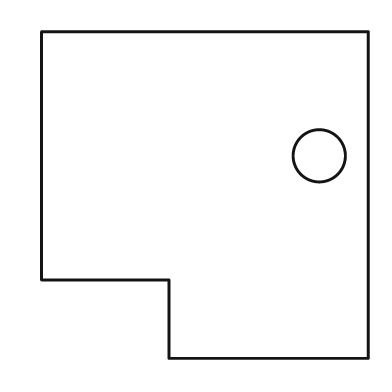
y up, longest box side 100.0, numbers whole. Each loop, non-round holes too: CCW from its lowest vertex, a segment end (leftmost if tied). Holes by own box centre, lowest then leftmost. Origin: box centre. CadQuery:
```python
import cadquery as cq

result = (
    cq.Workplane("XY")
    .moveTo(-11.0, -50.0)
    .lineTo(50.0, -50.0)
    .lineTo(50.0, 50.0)
    .lineTo(-50.0, 50.0)
    .lineTo(-50.0, -26.0)
    .lineTo(-11.0, -26.0)
    .close()
    .moveTo(35.0, 12.0)
    .circle(8.0)
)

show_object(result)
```